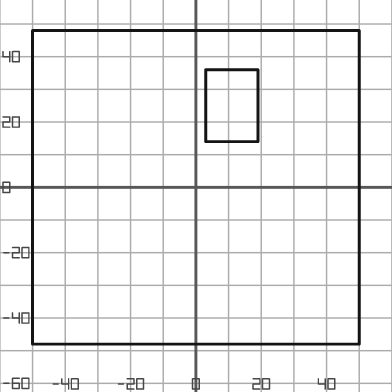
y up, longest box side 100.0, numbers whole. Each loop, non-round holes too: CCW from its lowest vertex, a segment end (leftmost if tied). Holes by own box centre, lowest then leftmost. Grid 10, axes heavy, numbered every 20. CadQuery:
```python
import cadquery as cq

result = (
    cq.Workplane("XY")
    .moveTo(-50.0, -48.0)
    .lineTo(50.0, -48.0)
    .lineTo(50.0, 48.0)
    .lineTo(-50.0, 48.0)
    .close()
    .moveTo(3.0, 14.0)
    .lineTo(19.0, 14.0)
    .lineTo(19.0, 36.0)
    .lineTo(3.0, 36.0)
    .close()
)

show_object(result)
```